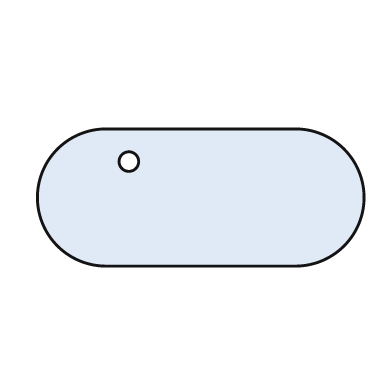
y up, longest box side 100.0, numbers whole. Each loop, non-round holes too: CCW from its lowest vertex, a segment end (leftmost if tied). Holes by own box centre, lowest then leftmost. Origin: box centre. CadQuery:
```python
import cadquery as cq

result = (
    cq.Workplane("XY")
    .moveTo(-29.0, -21.0)
    .lineTo(29.0, -21.0)
    .threePointArc((50.0, 0.0), (29.0, 21.0))
    .lineTo(-29.0, 21.0)
    .threePointArc((-50.0, 0.0), (-29.0, -21.0))
    .close()
    .moveTo(-22.0, 11.0)
    .circle(3.0)
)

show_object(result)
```